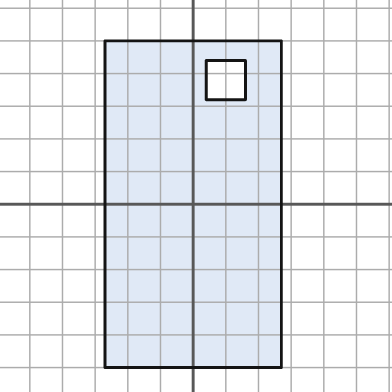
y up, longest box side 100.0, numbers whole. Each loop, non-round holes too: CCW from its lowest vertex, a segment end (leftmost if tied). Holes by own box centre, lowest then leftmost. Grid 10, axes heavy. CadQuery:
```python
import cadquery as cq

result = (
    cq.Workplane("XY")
    .moveTo(-27.0, -50.0)
    .lineTo(27.0, -50.0)
    .lineTo(27.0, 50.0)
    .lineTo(-27.0, 50.0)
    .close()
    .moveTo(4.0, 32.0)
    .lineTo(16.0, 32.0)
    .lineTo(16.0, 44.0)
    .lineTo(4.0, 44.0)
    .close()
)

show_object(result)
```